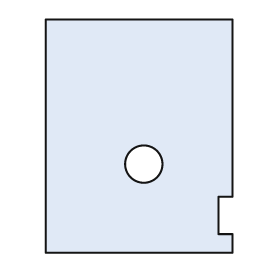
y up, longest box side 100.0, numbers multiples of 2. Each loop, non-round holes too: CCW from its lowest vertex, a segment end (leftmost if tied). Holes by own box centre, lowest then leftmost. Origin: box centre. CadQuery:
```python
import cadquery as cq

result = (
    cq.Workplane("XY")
    .moveTo(-40.0, -50.0)
    .lineTo(40.0, -50.0)
    .lineTo(40.0, -42.0)
    .lineTo(34.0, -42.0)
    .lineTo(34.0, -26.0)
    .lineTo(40.0, -26.0)
    .lineTo(40.0, 50.0)
    .lineTo(-40.0, 50.0)
    .close()
    .moveTo(2.0, -12.0)
    .circle(8.0)
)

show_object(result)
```